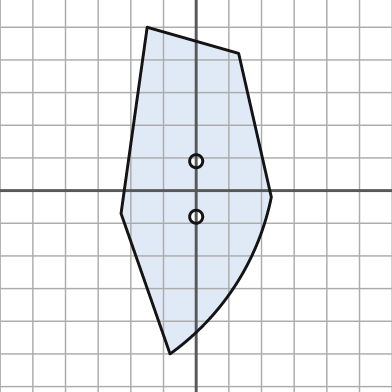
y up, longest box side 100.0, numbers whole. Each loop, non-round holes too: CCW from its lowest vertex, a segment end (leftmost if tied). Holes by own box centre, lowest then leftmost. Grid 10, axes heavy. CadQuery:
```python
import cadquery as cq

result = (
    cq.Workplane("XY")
    .moveTo(-8.0, -50.0)
    .threePointArc((12.0, -29.0), (23.0, -2.0))
    .lineTo(13.0, 42.0)
    .lineTo(-15.0, 50.0)
    .lineTo(-23.0, -7.0)
    .close()
    .moveTo(0.0, -8.0)
    .circle(2.0)
    .moveTo(0.0, 9.0)
    .circle(2.0)
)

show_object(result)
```